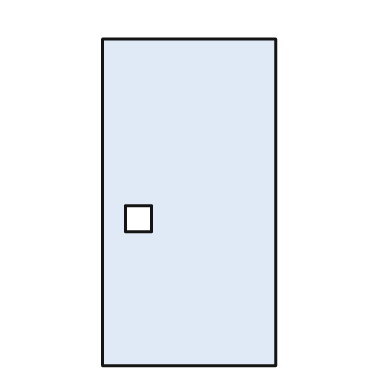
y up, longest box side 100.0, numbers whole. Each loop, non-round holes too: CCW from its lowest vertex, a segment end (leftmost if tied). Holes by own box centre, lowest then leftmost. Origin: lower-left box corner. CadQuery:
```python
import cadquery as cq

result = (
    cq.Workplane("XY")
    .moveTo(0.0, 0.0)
    .lineTo(53.0, 0.0)
    .lineTo(53.0, 100.0)
    .lineTo(0.0, 100.0)
    .close()
    .moveTo(7.0, 41.0)
    .lineTo(15.0, 41.0)
    .lineTo(15.0, 49.0)
    .lineTo(7.0, 49.0)
    .close()
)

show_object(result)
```